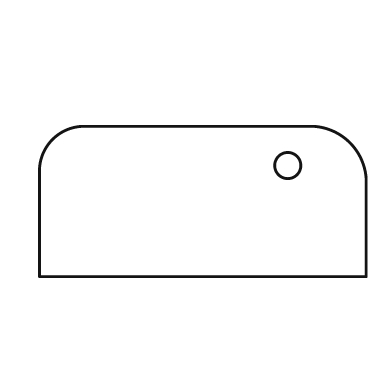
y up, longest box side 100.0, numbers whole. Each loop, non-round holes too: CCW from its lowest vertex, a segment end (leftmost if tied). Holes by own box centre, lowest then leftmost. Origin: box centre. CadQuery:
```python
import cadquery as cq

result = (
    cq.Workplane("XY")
    .moveTo(-50.0, -23.0)
    .lineTo(50.0, -23.0)
    .lineTo(50.0, 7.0)
    .threePointArc((45.0, 18.0), (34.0, 23.0))
    .lineTo(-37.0, 23.0)
    .threePointArc((-46.0, 19.0), (-50.0, 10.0))
    .close()
    .moveTo(26.0, 11.0)
    .circle(4.0)
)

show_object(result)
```